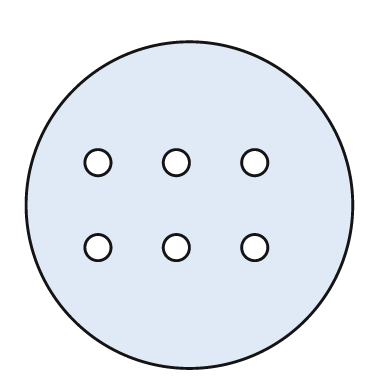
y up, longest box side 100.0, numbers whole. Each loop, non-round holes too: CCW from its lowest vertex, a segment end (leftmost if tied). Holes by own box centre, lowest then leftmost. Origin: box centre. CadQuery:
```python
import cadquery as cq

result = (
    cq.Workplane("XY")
    .moveTo(0.0, 0.0)
    .circle(50.0)
    .moveTo(-28.0, -13.0)
    .circle(4.0)
    .moveTo(-4.0, -13.0)
    .circle(4.0)
    .moveTo(20.0, -13.0)
    .circle(4.0)
    .moveTo(-28.0, 13.0)
    .circle(4.0)
    .moveTo(-4.0, 13.0)
    .circle(4.0)
    .moveTo(20.0, 13.0)
    .circle(4.0)
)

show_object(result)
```